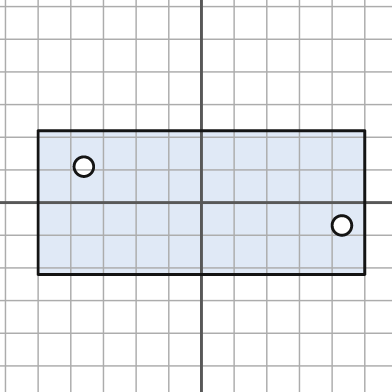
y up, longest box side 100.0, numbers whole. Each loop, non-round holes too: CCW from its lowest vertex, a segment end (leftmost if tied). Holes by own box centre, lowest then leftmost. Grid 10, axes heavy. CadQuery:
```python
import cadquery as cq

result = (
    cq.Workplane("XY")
    .moveTo(-50.0, -22.0)
    .lineTo(50.0, -22.0)
    .lineTo(50.0, 22.0)
    .lineTo(-50.0, 22.0)
    .close()
    .moveTo(43.0, -7.0)
    .circle(3.0)
    .moveTo(-36.0, 11.0)
    .circle(3.0)
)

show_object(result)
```